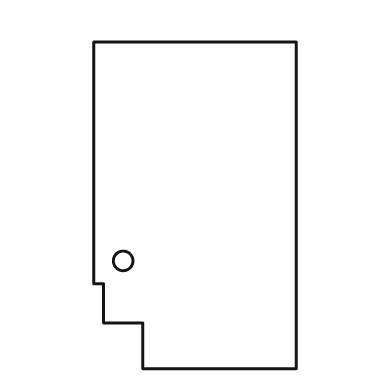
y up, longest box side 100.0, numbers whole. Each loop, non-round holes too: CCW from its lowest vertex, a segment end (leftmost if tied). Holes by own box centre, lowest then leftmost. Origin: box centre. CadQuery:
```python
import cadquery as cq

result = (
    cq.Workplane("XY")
    .moveTo(-16.0, -50.0)
    .lineTo(31.0, -50.0)
    .lineTo(31.0, 50.0)
    .lineTo(-31.0, 50.0)
    .lineTo(-31.0, -24.0)
    .lineTo(-28.0, -24.0)
    .lineTo(-28.0, -36.0)
    .lineTo(-16.0, -36.0)
    .close()
    .moveTo(-22.0, -17.0)
    .circle(3.0)
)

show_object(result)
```